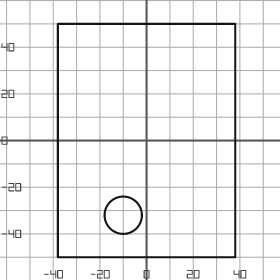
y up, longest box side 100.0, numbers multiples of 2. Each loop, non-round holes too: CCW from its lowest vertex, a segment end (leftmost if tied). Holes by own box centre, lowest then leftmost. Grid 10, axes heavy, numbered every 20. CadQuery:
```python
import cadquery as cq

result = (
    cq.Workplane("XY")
    .moveTo(-38.0, -50.0)
    .lineTo(38.0, -50.0)
    .lineTo(38.0, 50.0)
    .lineTo(-38.0, 50.0)
    .close()
    .moveTo(-10.0, -32.0)
    .circle(8.0)
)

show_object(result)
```